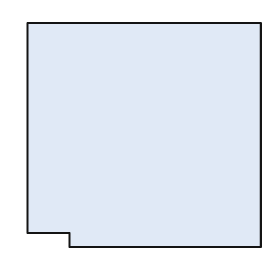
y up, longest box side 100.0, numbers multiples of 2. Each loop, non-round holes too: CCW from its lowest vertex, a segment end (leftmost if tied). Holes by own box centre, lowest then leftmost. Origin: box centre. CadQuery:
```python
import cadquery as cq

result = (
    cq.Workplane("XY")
    .moveTo(-32.0, -48.0)
    .lineTo(50.0, -48.0)
    .lineTo(50.0, 48.0)
    .lineTo(-50.0, 48.0)
    .lineTo(-50.0, -42.0)
    .lineTo(-32.0, -42.0)
    .close()
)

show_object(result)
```